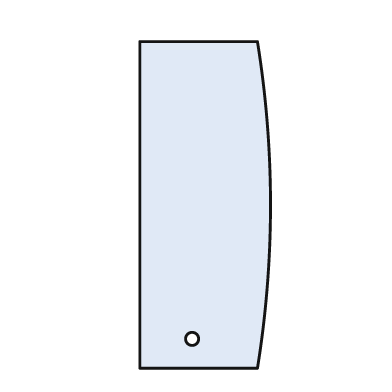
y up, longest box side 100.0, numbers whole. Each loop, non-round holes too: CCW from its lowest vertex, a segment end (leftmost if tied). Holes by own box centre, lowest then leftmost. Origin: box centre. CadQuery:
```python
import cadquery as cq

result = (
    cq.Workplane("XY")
    .moveTo(-20.0, -50.0)
    .lineTo(16.0, -50.0)
    .threePointArc((20.0, 0.0), (16.0, 50.0))
    .lineTo(-20.0, 50.0)
    .close()
    .moveTo(-4.0, -41.0)
    .circle(2.0)
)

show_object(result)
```